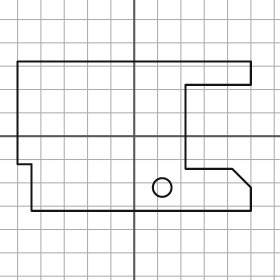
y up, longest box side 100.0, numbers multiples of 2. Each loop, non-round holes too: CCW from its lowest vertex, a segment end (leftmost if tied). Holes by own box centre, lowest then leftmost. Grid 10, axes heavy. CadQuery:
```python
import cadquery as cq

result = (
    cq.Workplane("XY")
    .moveTo(-44.0, -32.0)
    .lineTo(50.0, -32.0)
    .lineTo(50.0, -22.0)
    .lineTo(42.0, -14.0)
    .lineTo(22.0, -14.0)
    .lineTo(22.0, 22.0)
    .lineTo(50.0, 22.0)
    .lineTo(50.0, 32.0)
    .lineTo(-50.0, 32.0)
    .lineTo(-50.0, -12.0)
    .lineTo(-44.0, -12.0)
    .close()
    .moveTo(12.0, -22.0)
    .circle(4.0)
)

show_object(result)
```